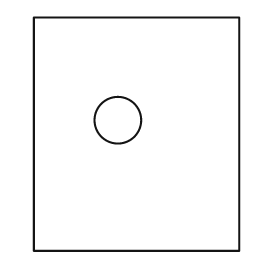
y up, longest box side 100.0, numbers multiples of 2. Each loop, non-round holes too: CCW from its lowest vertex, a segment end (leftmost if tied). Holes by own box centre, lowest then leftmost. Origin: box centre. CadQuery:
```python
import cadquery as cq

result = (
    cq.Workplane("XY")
    .moveTo(-44.0, -50.0)
    .lineTo(44.0, -50.0)
    .lineTo(44.0, 50.0)
    .lineTo(-44.0, 50.0)
    .close()
    .moveTo(-8.0, 6.0)
    .circle(10.0)
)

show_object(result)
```